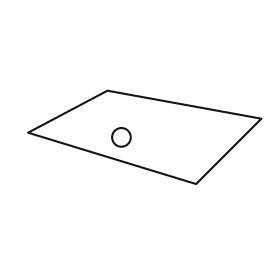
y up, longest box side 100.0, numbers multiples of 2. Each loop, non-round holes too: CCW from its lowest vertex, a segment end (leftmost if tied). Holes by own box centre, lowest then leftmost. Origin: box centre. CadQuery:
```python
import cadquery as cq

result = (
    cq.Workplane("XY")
    .moveTo(22.0, -20.0)
    .lineTo(50.0, 8.0)
    .lineTo(-16.0, 20.0)
    .lineTo(-50.0, 2.0)
    .close()
    .moveTo(-10.0, 0.0)
    .circle(4.0)
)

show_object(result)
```